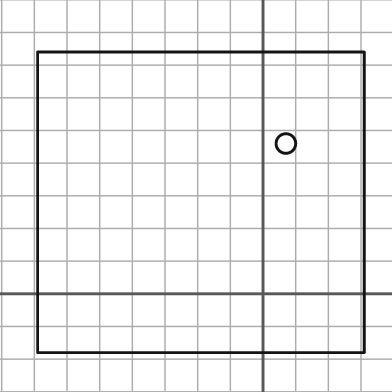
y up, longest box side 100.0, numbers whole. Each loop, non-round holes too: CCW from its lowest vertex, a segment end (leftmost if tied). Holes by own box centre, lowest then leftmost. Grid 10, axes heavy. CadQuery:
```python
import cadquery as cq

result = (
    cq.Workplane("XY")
    .moveTo(-69.0, -18.0)
    .lineTo(31.0, -18.0)
    .lineTo(31.0, 74.0)
    .lineTo(-69.0, 74.0)
    .close()
    .moveTo(7.0, 46.0)
    .circle(3.0)
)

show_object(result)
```